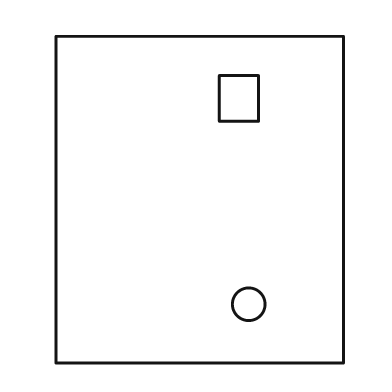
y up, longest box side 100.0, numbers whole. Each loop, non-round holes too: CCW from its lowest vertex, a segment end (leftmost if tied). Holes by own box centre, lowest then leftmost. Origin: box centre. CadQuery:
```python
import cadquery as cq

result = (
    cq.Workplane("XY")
    .moveTo(-44.0, -50.0)
    .lineTo(44.0, -50.0)
    .lineTo(44.0, 50.0)
    .lineTo(-44.0, 50.0)
    .close()
    .moveTo(15.0, -32.0)
    .circle(5.0)
    .moveTo(6.0, 24.0)
    .lineTo(18.0, 24.0)
    .lineTo(18.0, 38.0)
    .lineTo(6.0, 38.0)
    .close()
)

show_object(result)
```